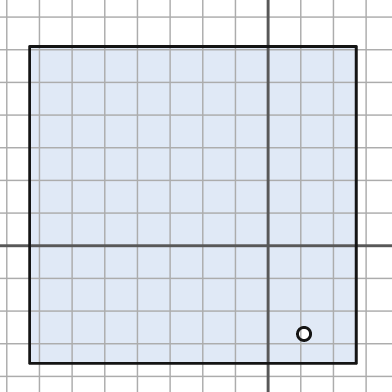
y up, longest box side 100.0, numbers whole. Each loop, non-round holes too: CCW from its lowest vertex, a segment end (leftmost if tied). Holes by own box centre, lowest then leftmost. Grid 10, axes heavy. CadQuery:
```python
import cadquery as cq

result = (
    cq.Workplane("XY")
    .moveTo(-73.0, -36.0)
    .lineTo(27.0, -36.0)
    .lineTo(27.0, 61.0)
    .lineTo(-73.0, 61.0)
    .close()
    .moveTo(11.0, -27.0)
    .circle(2.0)
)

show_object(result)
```